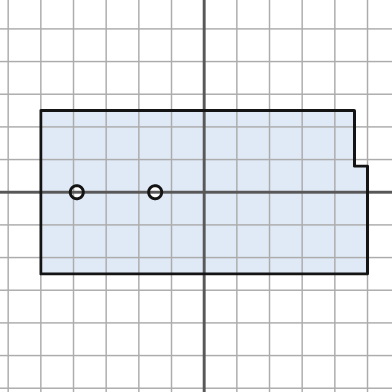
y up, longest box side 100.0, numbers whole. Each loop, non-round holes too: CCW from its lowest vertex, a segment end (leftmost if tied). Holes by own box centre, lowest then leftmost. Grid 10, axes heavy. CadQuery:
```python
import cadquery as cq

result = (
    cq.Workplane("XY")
    .moveTo(-50.0, -25.0)
    .lineTo(50.0, -25.0)
    .lineTo(50.0, 8.0)
    .lineTo(46.0, 8.0)
    .lineTo(46.0, 25.0)
    .lineTo(-50.0, 25.0)
    .close()
    .moveTo(-39.0, 0.0)
    .circle(2.0)
    .moveTo(-15.0, 0.0)
    .circle(2.0)
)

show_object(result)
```